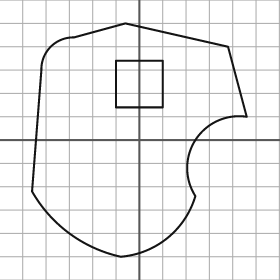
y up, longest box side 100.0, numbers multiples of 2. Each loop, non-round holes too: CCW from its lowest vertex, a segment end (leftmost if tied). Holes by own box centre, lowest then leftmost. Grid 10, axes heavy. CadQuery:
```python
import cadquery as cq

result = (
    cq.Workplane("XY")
    .moveTo(-8.0, -50.0)
    .threePointArc((12.0, -42.0), (24.0, -24.0))
    .threePointArc((24.0, 0.0), (46.0, 10.0))
    .lineTo(38.0, 40.0)
    .lineTo(-6.0, 50.0)
    .lineTo(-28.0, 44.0)
    .threePointArc((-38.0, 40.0), (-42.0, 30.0))
    .lineTo(-46.0, -22.0)
    .threePointArc((-30.0, -40.0), (-8.0, -50.0))
    .close()
    .moveTo(-10.0, 14.0)
    .lineTo(10.0, 14.0)
    .lineTo(10.0, 34.0)
    .lineTo(-10.0, 34.0)
    .close()
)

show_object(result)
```